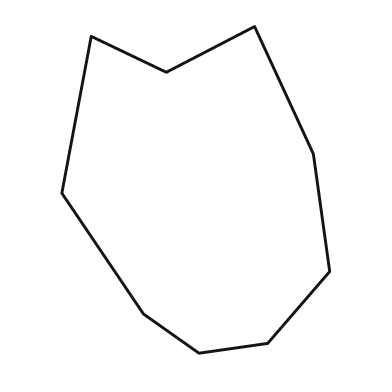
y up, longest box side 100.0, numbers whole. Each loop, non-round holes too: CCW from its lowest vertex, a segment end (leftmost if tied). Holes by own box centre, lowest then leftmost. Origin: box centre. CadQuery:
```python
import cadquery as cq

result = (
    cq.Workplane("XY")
    .moveTo(1.0, -50.0)
    .lineTo(22.0, -47.0)
    .lineTo(41.0, -25.0)
    .lineTo(36.0, 11.0)
    .lineTo(18.0, 50.0)
    .lineTo(-9.0, 36.0)
    .lineTo(-32.0, 47.0)
    .lineTo(-41.0, -1.0)
    .lineTo(-16.0, -38.0)
    .close()
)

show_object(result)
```